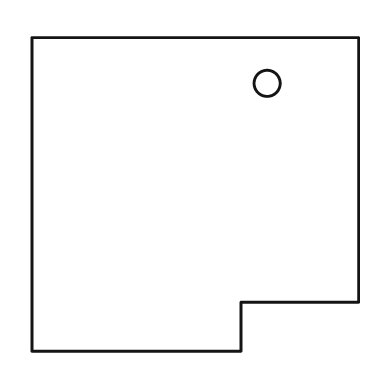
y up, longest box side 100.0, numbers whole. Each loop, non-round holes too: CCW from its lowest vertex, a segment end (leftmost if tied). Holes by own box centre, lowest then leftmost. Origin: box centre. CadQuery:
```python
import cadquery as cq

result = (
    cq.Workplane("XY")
    .moveTo(-50.0, -48.0)
    .lineTo(14.0, -48.0)
    .lineTo(14.0, -33.0)
    .lineTo(50.0, -33.0)
    .lineTo(50.0, 48.0)
    .lineTo(-50.0, 48.0)
    .close()
    .moveTo(22.0, 34.0)
    .circle(4.0)
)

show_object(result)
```